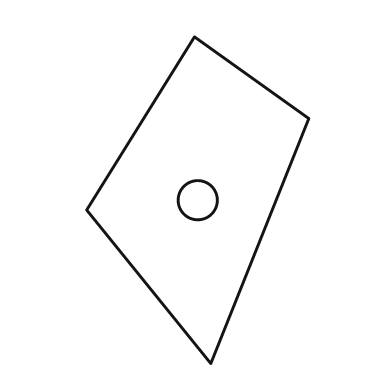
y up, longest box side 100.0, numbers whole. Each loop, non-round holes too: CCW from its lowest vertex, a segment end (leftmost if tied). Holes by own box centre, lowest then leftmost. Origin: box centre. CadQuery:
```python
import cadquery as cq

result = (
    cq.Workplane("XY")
    .moveTo(4.0, -50.0)
    .lineTo(34.0, 25.0)
    .lineTo(-1.0, 50.0)
    .lineTo(-34.0, -3.0)
    .close()
    .moveTo(0.0, 0.0)
    .circle(6.0)
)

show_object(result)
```